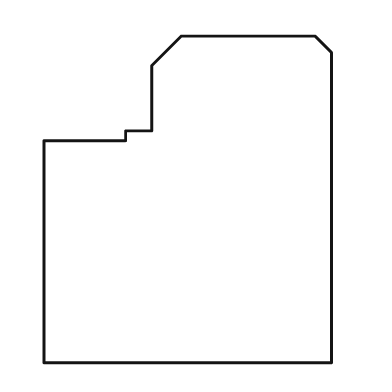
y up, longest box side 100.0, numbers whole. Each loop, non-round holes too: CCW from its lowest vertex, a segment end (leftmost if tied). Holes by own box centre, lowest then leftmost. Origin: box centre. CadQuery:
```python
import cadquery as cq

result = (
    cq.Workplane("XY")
    .moveTo(-44.0, -50.0)
    .lineTo(44.0, -50.0)
    .lineTo(44.0, 45.0)
    .lineTo(39.0, 50.0)
    .lineTo(-2.0, 50.0)
    .lineTo(-11.0, 41.0)
    .lineTo(-11.0, 21.0)
    .lineTo(-19.0, 21.0)
    .lineTo(-19.0, 18.0)
    .lineTo(-44.0, 18.0)
    .close()
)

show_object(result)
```